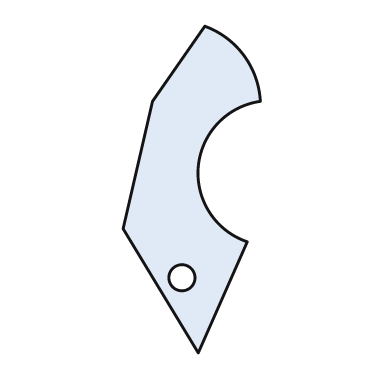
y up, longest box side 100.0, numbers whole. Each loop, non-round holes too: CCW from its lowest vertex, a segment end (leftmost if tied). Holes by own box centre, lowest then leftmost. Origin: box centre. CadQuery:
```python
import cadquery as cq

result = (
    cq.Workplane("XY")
    .moveTo(2.0, -50.0)
    .lineTo(17.0, -16.0)
    .threePointArc((2.0, 7.0), (21.0, 27.0))
    .threePointArc((16.0, 41.0), (4.0, 50.0))
    .lineTo(-12.0, 27.0)
    .lineTo(-21.0, -12.0)
    .close()
    .moveTo(-3.0, -27.0)
    .circle(4.0)
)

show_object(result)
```